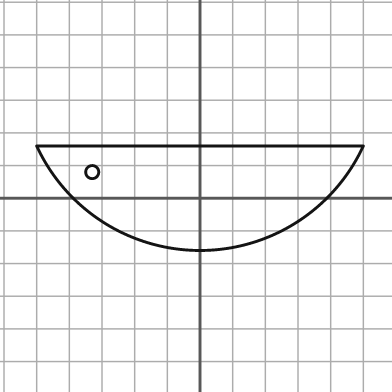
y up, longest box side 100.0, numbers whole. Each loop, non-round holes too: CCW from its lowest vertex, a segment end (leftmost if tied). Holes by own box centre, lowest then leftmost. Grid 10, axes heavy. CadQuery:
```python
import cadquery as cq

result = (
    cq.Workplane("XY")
    .moveTo(-50.0, 16.0)
    .threePointArc((0.0, -16.0), (50.0, 16.0))
    .close()
    .moveTo(-33.0, 8.0)
    .circle(2.0)
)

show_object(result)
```